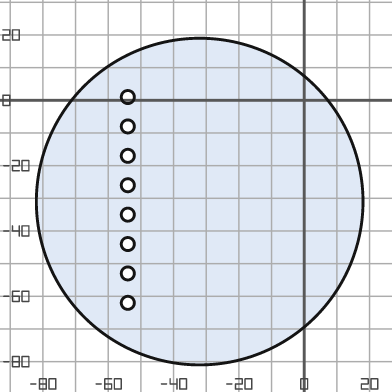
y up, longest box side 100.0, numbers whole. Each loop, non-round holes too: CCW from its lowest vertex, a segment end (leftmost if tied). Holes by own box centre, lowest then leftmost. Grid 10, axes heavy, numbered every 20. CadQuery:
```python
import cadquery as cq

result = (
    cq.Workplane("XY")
    .moveTo(-32.0, -31.0)
    .circle(50.0)
    .moveTo(-54.0, -62.0)
    .circle(2.0)
    .moveTo(-54.0, -53.0)
    .circle(2.0)
    .moveTo(-54.0, -44.0)
    .circle(2.0)
    .moveTo(-54.0, -35.0)
    .circle(2.0)
    .moveTo(-54.0, -26.0)
    .circle(2.0)
    .moveTo(-54.0, -17.0)
    .circle(2.0)
    .moveTo(-54.0, -8.0)
    .circle(2.0)
    .moveTo(-54.0, 1.0)
    .circle(2.0)
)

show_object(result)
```